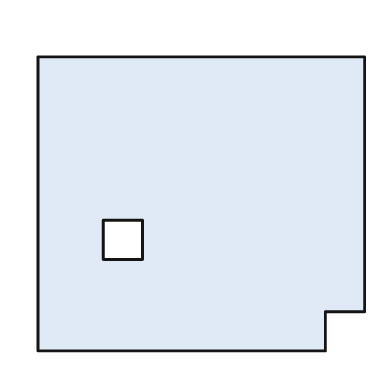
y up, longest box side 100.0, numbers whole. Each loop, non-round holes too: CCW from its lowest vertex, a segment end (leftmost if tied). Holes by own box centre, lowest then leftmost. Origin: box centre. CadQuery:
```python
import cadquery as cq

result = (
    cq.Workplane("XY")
    .moveTo(-50.0, -45.0)
    .lineTo(38.0, -45.0)
    .lineTo(38.0, -33.0)
    .lineTo(50.0, -33.0)
    .lineTo(50.0, 45.0)
    .lineTo(-50.0, 45.0)
    .close()
    .moveTo(-30.0, -17.0)
    .lineTo(-18.0, -17.0)
    .lineTo(-18.0, -5.0)
    .lineTo(-30.0, -5.0)
    .close()
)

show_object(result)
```